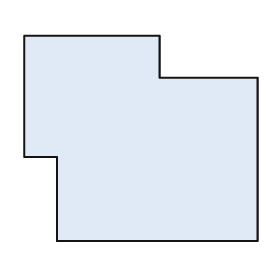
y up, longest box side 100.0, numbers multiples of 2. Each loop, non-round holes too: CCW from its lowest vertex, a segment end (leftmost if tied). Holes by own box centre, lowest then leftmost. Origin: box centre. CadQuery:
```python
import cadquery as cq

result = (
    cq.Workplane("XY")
    .moveTo(-36.0, -44.0)
    .lineTo(50.0, -44.0)
    .lineTo(50.0, 26.0)
    .lineTo(8.0, 26.0)
    .lineTo(8.0, 44.0)
    .lineTo(-50.0, 44.0)
    .lineTo(-50.0, -8.0)
    .lineTo(-36.0, -8.0)
    .close()
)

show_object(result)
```